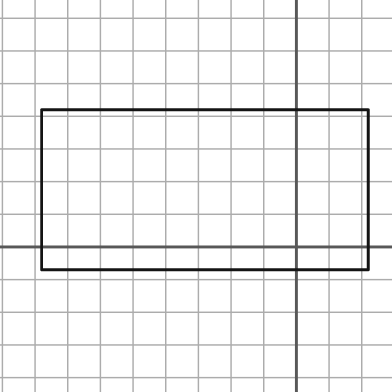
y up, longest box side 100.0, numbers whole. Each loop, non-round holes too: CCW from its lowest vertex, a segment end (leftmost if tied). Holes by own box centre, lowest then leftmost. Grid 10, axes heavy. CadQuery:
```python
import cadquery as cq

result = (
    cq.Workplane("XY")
    .moveTo(-78.0, -7.0)
    .lineTo(22.0, -7.0)
    .lineTo(22.0, 42.0)
    .lineTo(-78.0, 42.0)
    .close()
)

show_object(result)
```